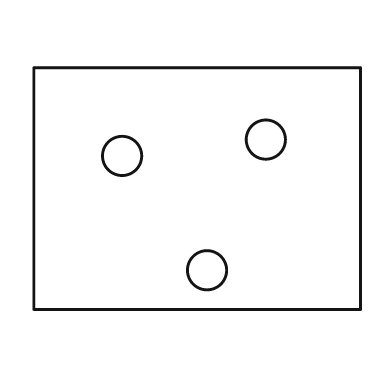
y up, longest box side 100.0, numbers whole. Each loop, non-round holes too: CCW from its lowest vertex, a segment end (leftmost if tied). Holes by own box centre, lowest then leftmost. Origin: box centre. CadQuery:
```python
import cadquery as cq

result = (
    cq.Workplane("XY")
    .moveTo(-50.0, -37.0)
    .lineTo(50.0, -37.0)
    .lineTo(50.0, 37.0)
    .lineTo(-50.0, 37.0)
    .close()
    .moveTo(3.0, -25.0)
    .circle(6.0)
    .moveTo(-23.0, 10.0)
    .circle(6.0)
    .moveTo(21.0, 15.0)
    .circle(6.0)
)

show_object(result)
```